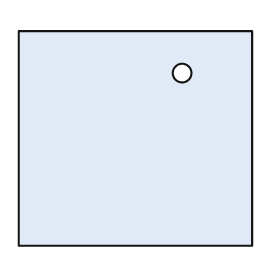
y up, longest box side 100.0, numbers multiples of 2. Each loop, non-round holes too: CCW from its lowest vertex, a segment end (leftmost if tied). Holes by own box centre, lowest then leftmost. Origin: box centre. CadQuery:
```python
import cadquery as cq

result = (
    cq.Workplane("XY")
    .moveTo(-50.0, -46.0)
    .lineTo(50.0, -46.0)
    .lineTo(50.0, 46.0)
    .lineTo(-50.0, 46.0)
    .close()
    .moveTo(20.0, 28.0)
    .circle(4.0)
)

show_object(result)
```